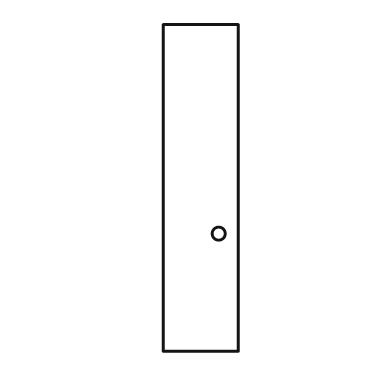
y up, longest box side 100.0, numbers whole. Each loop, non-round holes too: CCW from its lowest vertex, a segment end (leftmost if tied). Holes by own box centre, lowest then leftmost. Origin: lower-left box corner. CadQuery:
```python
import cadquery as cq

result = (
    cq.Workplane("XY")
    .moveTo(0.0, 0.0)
    .lineTo(23.0, 0.0)
    .lineTo(23.0, 100.0)
    .lineTo(0.0, 100.0)
    .close()
    .moveTo(17.0, 36.0)
    .circle(2.0)
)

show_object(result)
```